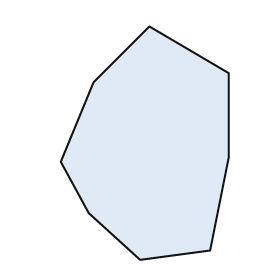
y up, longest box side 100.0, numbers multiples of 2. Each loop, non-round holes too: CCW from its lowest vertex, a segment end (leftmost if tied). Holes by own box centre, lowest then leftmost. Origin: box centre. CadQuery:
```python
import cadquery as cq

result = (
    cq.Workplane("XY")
    .moveTo(-2.0, -50.0)
    .lineTo(28.0, -46.0)
    .lineTo(36.0, -6.0)
    .lineTo(36.0, 30.0)
    .lineTo(2.0, 50.0)
    .lineTo(-22.0, 26.0)
    .lineTo(-36.0, -8.0)
    .lineTo(-24.0, -30.0)
    .close()
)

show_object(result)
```